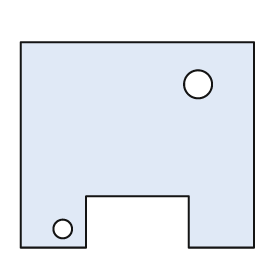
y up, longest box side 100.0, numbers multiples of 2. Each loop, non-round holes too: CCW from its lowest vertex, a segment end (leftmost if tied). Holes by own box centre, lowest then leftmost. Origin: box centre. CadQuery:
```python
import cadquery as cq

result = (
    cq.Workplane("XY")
    .moveTo(-50.0, -44.0)
    .lineTo(-22.0, -44.0)
    .lineTo(-22.0, -22.0)
    .lineTo(22.0, -22.0)
    .lineTo(22.0, -44.0)
    .lineTo(50.0, -44.0)
    .lineTo(50.0, 44.0)
    .lineTo(-50.0, 44.0)
    .close()
    .moveTo(-32.0, -36.0)
    .circle(4.0)
    .moveTo(26.0, 26.0)
    .circle(6.0)
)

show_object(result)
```